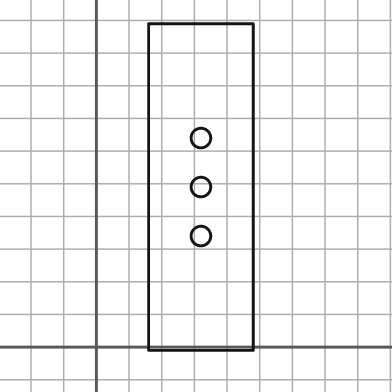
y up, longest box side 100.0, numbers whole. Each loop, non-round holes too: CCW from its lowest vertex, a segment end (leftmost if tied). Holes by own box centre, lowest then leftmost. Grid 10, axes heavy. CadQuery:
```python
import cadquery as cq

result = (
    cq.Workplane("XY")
    .moveTo(16.0, -1.0)
    .lineTo(48.0, -1.0)
    .lineTo(48.0, 99.0)
    .lineTo(16.0, 99.0)
    .close()
    .moveTo(32.0, 34.0)
    .circle(3.0)
    .moveTo(32.0, 49.0)
    .circle(3.0)
    .moveTo(32.0, 64.0)
    .circle(3.0)
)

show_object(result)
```